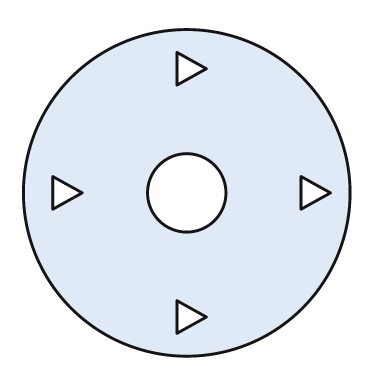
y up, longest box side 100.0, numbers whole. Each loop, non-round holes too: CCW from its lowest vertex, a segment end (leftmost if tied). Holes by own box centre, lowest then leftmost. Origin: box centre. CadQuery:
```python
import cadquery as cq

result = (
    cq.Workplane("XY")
    .moveTo(0.0, 0.0)
    .circle(50.0)
    .moveTo(-3.0, -43.0)
    .lineTo(6.0, -38.0)
    .lineTo(-3.0, -33.0)
    .close()
    .moveTo(-41.0, -5.0)
    .lineTo(-32.0, 0.0)
    .lineTo(-41.0, 5.0)
    .close()
    .moveTo(0.0, 0.0)
    .circle(12.0)
    .moveTo(35.0, -5.0)
    .lineTo(44.0, 0.0)
    .lineTo(35.0, 5.0)
    .close()
    .moveTo(-3.0, 33.0)
    .lineTo(6.0, 38.0)
    .lineTo(-3.0, 43.0)
    .close()
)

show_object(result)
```